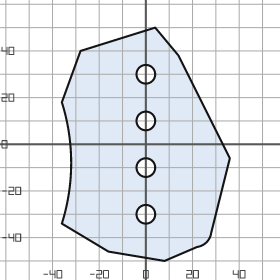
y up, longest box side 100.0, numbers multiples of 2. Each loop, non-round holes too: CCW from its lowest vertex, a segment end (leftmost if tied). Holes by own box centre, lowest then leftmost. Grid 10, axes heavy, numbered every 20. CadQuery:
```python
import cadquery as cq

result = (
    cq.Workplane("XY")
    .moveTo(8.0, -50.0)
    .lineTo(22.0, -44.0)
    .threePointArc((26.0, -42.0), (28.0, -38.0))
    .lineTo(36.0, -6.0)
    .lineTo(14.0, 38.0)
    .lineTo(4.0, 50.0)
    .lineTo(-28.0, 40.0)
    .lineTo(-36.0, 18.0)
    .threePointArc((-32.0, -8.0), (-36.0, -34.0))
    .lineTo(-16.0, -46.0)
    .close()
    .moveTo(0.0, -30.0)
    .circle(4.0)
    .moveTo(0.0, -10.0)
    .circle(4.0)
    .moveTo(0.0, 10.0)
    .circle(4.0)
    .moveTo(0.0, 30.0)
    .circle(4.0)
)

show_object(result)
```